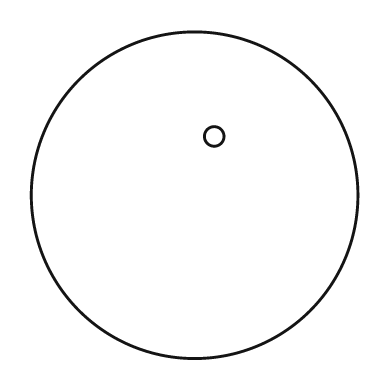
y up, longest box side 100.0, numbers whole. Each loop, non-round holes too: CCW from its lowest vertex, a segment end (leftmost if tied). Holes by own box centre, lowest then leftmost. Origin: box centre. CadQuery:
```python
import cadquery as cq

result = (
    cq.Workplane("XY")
    .moveTo(0.0, 0.0)
    .circle(50.0)
    .moveTo(6.0, 18.0)
    .circle(3.0)
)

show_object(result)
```